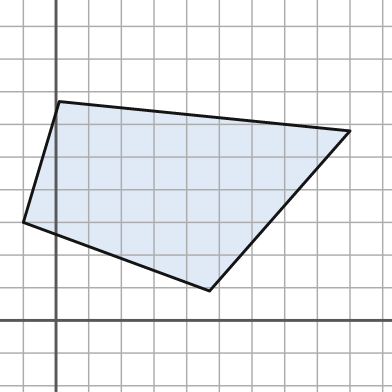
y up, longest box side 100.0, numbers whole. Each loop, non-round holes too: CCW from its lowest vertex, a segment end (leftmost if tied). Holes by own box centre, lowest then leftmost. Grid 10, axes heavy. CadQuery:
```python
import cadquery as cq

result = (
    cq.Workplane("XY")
    .moveTo(47.0, 9.0)
    .lineTo(90.0, 58.0)
    .lineTo(1.0, 67.0)
    .lineTo(-10.0, 30.0)
    .close()
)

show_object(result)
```